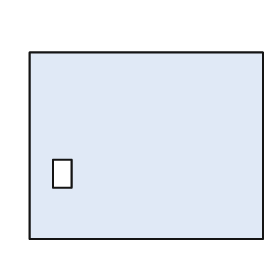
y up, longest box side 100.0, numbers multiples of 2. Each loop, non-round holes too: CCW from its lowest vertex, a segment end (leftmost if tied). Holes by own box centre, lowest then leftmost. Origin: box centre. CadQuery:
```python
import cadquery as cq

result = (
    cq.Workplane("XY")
    .moveTo(-50.0, -40.0)
    .lineTo(50.0, -40.0)
    .lineTo(50.0, 40.0)
    .lineTo(-50.0, 40.0)
    .close()
    .moveTo(-40.0, -18.0)
    .lineTo(-32.0, -18.0)
    .lineTo(-32.0, -6.0)
    .lineTo(-40.0, -6.0)
    .close()
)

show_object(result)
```